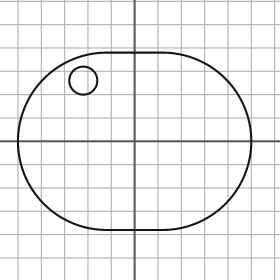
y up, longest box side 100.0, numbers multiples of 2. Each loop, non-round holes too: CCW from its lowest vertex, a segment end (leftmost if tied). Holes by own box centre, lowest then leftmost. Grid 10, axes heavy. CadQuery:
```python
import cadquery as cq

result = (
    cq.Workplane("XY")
    .moveTo(-12.0, -38.0)
    .lineTo(12.0, -38.0)
    .threePointArc((50.0, 0.0), (12.0, 38.0))
    .lineTo(-12.0, 38.0)
    .threePointArc((-50.0, 0.0), (-12.0, -38.0))
    .close()
    .moveTo(-22.0, 26.0)
    .circle(6.0)
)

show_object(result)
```